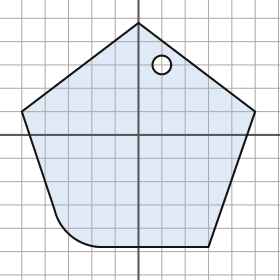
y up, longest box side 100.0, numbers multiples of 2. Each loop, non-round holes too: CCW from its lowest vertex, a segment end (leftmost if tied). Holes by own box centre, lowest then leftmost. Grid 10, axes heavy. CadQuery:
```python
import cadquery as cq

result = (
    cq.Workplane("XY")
    .moveTo(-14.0, -48.0)
    .lineTo(30.0, -48.0)
    .lineTo(50.0, 10.0)
    .lineTo(0.0, 48.0)
    .lineTo(-50.0, 10.0)
    .lineTo(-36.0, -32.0)
    .threePointArc((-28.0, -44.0), (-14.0, -48.0))
    .close()
    .moveTo(10.0, 30.0)
    .circle(4.0)
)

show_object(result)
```